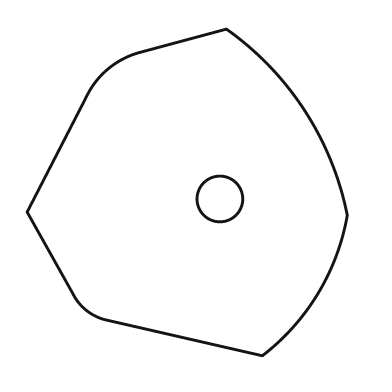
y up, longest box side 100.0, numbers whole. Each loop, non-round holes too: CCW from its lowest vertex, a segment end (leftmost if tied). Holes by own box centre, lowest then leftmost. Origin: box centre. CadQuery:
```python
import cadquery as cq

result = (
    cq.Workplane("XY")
    .moveTo(23.0, -50.0)
    .threePointArc((40.0, -31.0), (49.0, -7.0))
    .threePointArc((36.0, 25.0), (12.0, 50.0))
    .lineTo(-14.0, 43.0)
    .threePointArc((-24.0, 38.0), (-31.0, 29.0))
    .lineTo(-49.0, -6.0)
    .lineTo(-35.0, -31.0)
    .threePointArc((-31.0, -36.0), (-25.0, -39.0))
    .close()
    .moveTo(10.0, -2.0)
    .circle(7.0)
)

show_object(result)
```